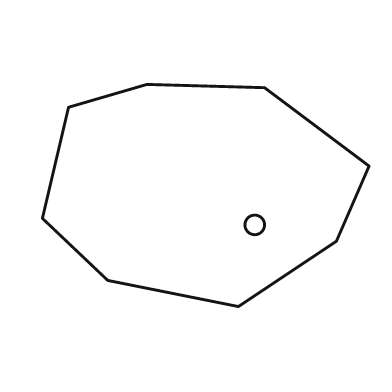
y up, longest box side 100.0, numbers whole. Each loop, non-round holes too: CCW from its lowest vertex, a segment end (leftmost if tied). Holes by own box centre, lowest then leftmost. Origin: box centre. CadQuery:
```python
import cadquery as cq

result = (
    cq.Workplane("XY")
    .moveTo(10.0, -34.0)
    .lineTo(40.0, -14.0)
    .lineTo(50.0, 9.0)
    .lineTo(18.0, 33.0)
    .lineTo(-18.0, 34.0)
    .lineTo(-42.0, 27.0)
    .lineTo(-50.0, -7.0)
    .lineTo(-30.0, -26.0)
    .close()
    .moveTo(15.0, -9.0)
    .circle(3.0)
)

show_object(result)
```